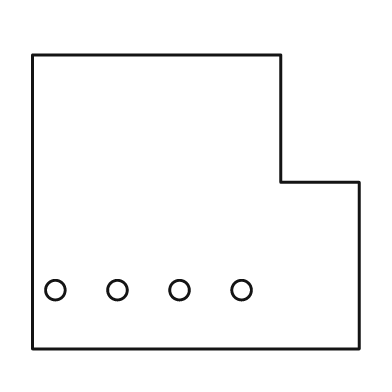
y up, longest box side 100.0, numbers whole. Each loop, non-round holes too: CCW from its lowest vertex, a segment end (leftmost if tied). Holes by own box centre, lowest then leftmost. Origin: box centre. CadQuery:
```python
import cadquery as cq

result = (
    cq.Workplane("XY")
    .moveTo(-50.0, -45.0)
    .lineTo(50.0, -45.0)
    .lineTo(50.0, 6.0)
    .lineTo(26.0, 6.0)
    .lineTo(26.0, 45.0)
    .lineTo(-50.0, 45.0)
    .close()
    .moveTo(-43.0, -27.0)
    .circle(3.0)
    .moveTo(-24.0, -27.0)
    .circle(3.0)
    .moveTo(-5.0, -27.0)
    .circle(3.0)
    .moveTo(14.0, -27.0)
    .circle(3.0)
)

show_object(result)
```